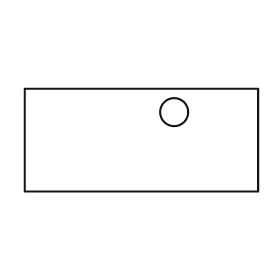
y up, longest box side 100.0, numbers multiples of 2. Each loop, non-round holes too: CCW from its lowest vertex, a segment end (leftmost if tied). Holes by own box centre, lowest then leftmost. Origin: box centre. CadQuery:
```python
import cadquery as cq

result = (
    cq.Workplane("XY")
    .moveTo(-50.0, -22.0)
    .lineTo(50.0, -22.0)
    .lineTo(50.0, 22.0)
    .lineTo(-50.0, 22.0)
    .close()
    .moveTo(14.0, 12.0)
    .circle(6.0)
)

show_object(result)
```